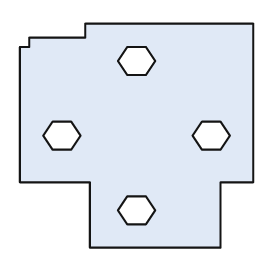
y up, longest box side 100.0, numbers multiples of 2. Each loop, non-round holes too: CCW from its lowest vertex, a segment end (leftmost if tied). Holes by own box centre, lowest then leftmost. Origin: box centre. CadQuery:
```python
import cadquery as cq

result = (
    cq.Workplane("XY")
    .moveTo(-20.0, -48.0)
    .lineTo(36.0, -48.0)
    .lineTo(36.0, -20.0)
    .lineTo(50.0, -20.0)
    .lineTo(50.0, 48.0)
    .lineTo(-22.0, 48.0)
    .lineTo(-22.0, 42.0)
    .lineTo(-46.0, 42.0)
    .lineTo(-46.0, 38.0)
    .lineTo(-50.0, 38.0)
    .lineTo(-50.0, -20.0)
    .lineTo(-20.0, -20.0)
    .close()
    .moveTo(-4.0, -38.0)
    .lineTo(4.0, -38.0)
    .lineTo(8.0, -32.0)
    .lineTo(4.0, -26.0)
    .lineTo(-4.0, -26.0)
    .lineTo(-8.0, -32.0)
    .close()
    .moveTo(-36.0, -6.0)
    .lineTo(-28.0, -6.0)
    .lineTo(-24.0, 0.0)
    .lineTo(-28.0, 6.0)
    .lineTo(-36.0, 6.0)
    .lineTo(-40.0, 0.0)
    .close()
    .moveTo(28.0, -6.0)
    .lineTo(36.0, -6.0)
    .lineTo(40.0, 0.0)
    .lineTo(36.0, 6.0)
    .lineTo(28.0, 6.0)
    .lineTo(24.0, 0.0)
    .close()
    .moveTo(-4.0, 26.0)
    .lineTo(4.0, 26.0)
    .lineTo(8.0, 32.0)
    .lineTo(4.0, 38.0)
    .lineTo(-4.0, 38.0)
    .lineTo(-8.0, 32.0)
    .close()
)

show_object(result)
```